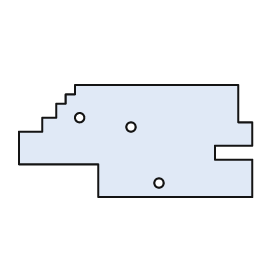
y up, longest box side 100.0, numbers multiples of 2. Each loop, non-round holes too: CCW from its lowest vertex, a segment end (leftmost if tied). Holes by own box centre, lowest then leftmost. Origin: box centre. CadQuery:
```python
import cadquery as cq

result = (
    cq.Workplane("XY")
    .moveTo(-16.0, -24.0)
    .lineTo(50.0, -24.0)
    .lineTo(50.0, -8.0)
    .lineTo(34.0, -8.0)
    .lineTo(34.0, -2.0)
    .lineTo(50.0, -2.0)
    .lineTo(50.0, 8.0)
    .lineTo(44.0, 8.0)
    .lineTo(44.0, 24.0)
    .lineTo(-26.0, 24.0)
    .lineTo(-26.0, 20.0)
    .lineTo(-30.0, 20.0)
    .lineTo(-30.0, 16.0)
    .lineTo(-34.0, 16.0)
    .lineTo(-34.0, 10.0)
    .lineTo(-40.0, 10.0)
    .lineTo(-40.0, 4.0)
    .lineTo(-50.0, 4.0)
    .lineTo(-50.0, -10.0)
    .lineTo(-16.0, -10.0)
    .close()
    .moveTo(10.0, -18.0)
    .circle(2.0)
    .moveTo(-2.0, 6.0)
    .circle(2.0)
    .moveTo(-24.0, 10.0)
    .circle(2.0)
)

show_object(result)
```